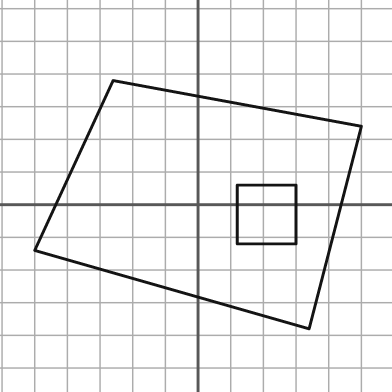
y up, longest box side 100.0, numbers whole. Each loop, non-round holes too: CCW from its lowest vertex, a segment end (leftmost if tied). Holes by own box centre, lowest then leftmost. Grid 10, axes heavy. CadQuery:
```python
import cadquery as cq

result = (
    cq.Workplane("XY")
    .moveTo(34.0, -38.0)
    .lineTo(50.0, 24.0)
    .lineTo(-26.0, 38.0)
    .lineTo(-50.0, -14.0)
    .close()
    .moveTo(12.0, -12.0)
    .lineTo(30.0, -12.0)
    .lineTo(30.0, 6.0)
    .lineTo(12.0, 6.0)
    .close()
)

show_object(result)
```